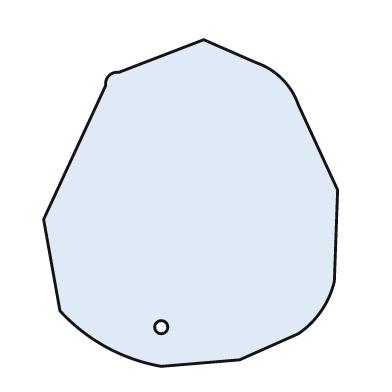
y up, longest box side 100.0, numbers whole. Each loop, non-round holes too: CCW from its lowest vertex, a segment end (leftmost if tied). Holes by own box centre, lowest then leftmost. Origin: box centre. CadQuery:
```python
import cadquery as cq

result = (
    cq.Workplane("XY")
    .moveTo(-9.0, -50.0)
    .lineTo(15.0, -48.0)
    .lineTo(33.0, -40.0)
    .threePointArc((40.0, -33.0), (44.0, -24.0))
    .lineTo(45.0, 4.0)
    .lineTo(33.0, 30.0)
    .threePointArc((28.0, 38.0), (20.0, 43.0))
    .lineTo(4.0, 50.0)
    .lineTo(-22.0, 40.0)
    .threePointArc((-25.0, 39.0), (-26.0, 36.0))
    .lineTo(-45.0, -5.0)
    .lineTo(-40.0, -33.0)
    .threePointArc((-26.0, -44.0), (-9.0, -50.0))
    .close()
    .moveTo(-9.0, -38.0)
    .circle(2.0)
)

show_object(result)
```